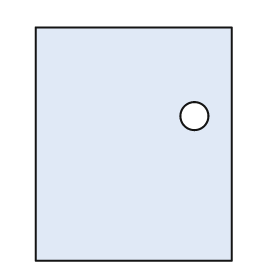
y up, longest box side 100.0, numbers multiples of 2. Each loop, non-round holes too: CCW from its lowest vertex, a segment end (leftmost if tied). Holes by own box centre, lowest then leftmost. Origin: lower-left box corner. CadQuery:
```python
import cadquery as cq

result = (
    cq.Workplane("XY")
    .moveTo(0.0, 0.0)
    .lineTo(84.0, 0.0)
    .lineTo(84.0, 100.0)
    .lineTo(0.0, 100.0)
    .close()
    .moveTo(68.0, 62.0)
    .circle(6.0)
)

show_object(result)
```